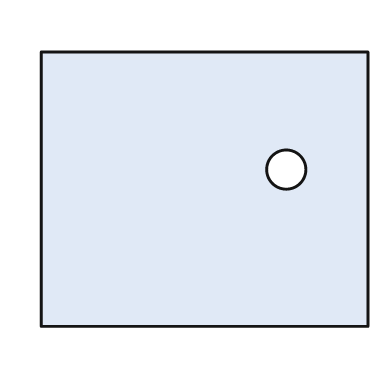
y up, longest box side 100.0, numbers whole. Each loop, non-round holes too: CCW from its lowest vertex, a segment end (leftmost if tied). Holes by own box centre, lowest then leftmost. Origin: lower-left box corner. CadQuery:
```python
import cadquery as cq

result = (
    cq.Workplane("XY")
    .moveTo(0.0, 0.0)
    .lineTo(100.0, 0.0)
    .lineTo(100.0, 84.0)
    .lineTo(0.0, 84.0)
    .close()
    .moveTo(75.0, 48.0)
    .circle(6.0)
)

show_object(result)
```